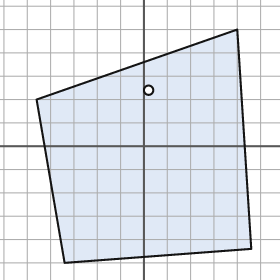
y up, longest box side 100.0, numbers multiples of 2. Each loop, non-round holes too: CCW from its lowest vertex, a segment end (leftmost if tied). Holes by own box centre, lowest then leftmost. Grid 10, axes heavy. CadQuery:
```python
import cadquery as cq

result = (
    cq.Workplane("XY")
    .moveTo(-34.0, -50.0)
    .lineTo(46.0, -44.0)
    .lineTo(40.0, 50.0)
    .lineTo(-46.0, 20.0)
    .close()
    .moveTo(2.0, 24.0)
    .circle(2.0)
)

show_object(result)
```